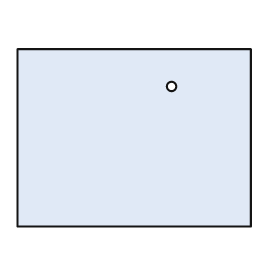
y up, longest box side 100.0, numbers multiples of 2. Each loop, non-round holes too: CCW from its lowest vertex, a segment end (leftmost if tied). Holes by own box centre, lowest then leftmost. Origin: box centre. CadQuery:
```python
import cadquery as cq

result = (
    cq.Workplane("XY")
    .moveTo(-50.0, -38.0)
    .lineTo(50.0, -38.0)
    .lineTo(50.0, 38.0)
    .lineTo(-50.0, 38.0)
    .close()
    .moveTo(16.0, 22.0)
    .circle(2.0)
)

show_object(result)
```